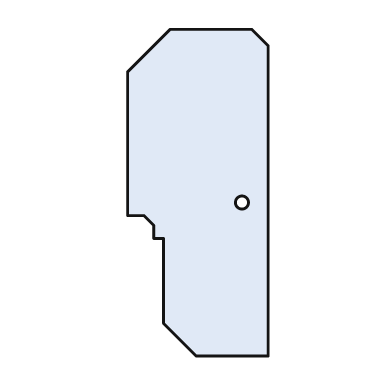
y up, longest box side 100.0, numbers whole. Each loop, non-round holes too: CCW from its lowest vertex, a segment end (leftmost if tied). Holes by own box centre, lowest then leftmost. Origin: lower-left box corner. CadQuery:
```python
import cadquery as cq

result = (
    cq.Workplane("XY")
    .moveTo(21.0, 0.0)
    .lineTo(43.0, 0.0)
    .lineTo(43.0, 95.0)
    .lineTo(38.0, 100.0)
    .lineTo(13.0, 100.0)
    .lineTo(0.0, 87.0)
    .lineTo(0.0, 43.0)
    .lineTo(5.0, 43.0)
    .lineTo(8.0, 40.0)
    .lineTo(8.0, 36.0)
    .lineTo(11.0, 36.0)
    .lineTo(11.0, 10.0)
    .close()
    .moveTo(35.0, 47.0)
    .circle(2.0)
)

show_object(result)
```